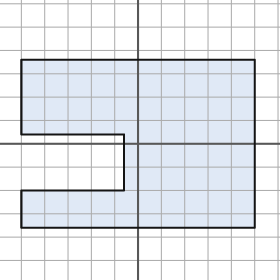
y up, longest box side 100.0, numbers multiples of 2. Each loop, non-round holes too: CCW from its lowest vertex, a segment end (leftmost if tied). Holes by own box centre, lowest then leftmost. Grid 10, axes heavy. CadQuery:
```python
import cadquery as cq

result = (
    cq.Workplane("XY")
    .moveTo(-50.0, -36.0)
    .lineTo(50.0, -36.0)
    .lineTo(50.0, 36.0)
    .lineTo(-50.0, 36.0)
    .lineTo(-50.0, 4.0)
    .lineTo(-6.0, 4.0)
    .lineTo(-6.0, -20.0)
    .lineTo(-50.0, -20.0)
    .close()
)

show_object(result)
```